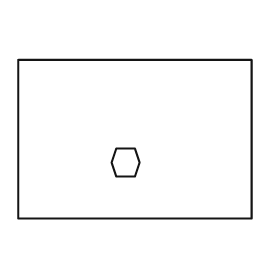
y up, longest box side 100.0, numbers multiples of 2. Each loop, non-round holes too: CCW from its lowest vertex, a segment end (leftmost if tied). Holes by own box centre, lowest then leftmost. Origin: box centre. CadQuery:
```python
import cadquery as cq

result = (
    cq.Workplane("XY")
    .moveTo(-50.0, -34.0)
    .lineTo(50.0, -34.0)
    .lineTo(50.0, 34.0)
    .lineTo(-50.0, 34.0)
    .close()
    .moveTo(-8.0, -16.0)
    .lineTo(0.0, -16.0)
    .lineTo(2.0, -10.0)
    .lineTo(0.0, -4.0)
    .lineTo(-8.0, -4.0)
    .lineTo(-10.0, -10.0)
    .close()
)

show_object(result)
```